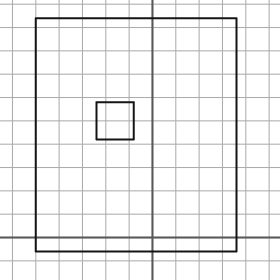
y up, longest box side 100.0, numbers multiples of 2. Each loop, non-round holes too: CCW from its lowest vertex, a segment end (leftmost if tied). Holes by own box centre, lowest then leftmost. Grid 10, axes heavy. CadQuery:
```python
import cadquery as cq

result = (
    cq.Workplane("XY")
    .moveTo(-50.0, -6.0)
    .lineTo(36.0, -6.0)
    .lineTo(36.0, 94.0)
    .lineTo(-50.0, 94.0)
    .close()
    .moveTo(-24.0, 42.0)
    .lineTo(-8.0, 42.0)
    .lineTo(-8.0, 58.0)
    .lineTo(-24.0, 58.0)
    .close()
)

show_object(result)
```